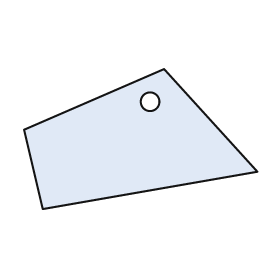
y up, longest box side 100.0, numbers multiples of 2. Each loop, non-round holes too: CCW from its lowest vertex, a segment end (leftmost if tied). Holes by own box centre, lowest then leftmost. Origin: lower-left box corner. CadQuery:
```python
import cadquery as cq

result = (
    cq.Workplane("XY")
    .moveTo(8.0, 0.0)
    .lineTo(100.0, 16.0)
    .lineTo(60.0, 60.0)
    .lineTo(0.0, 34.0)
    .close()
    .moveTo(54.0, 46.0)
    .circle(4.0)
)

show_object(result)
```